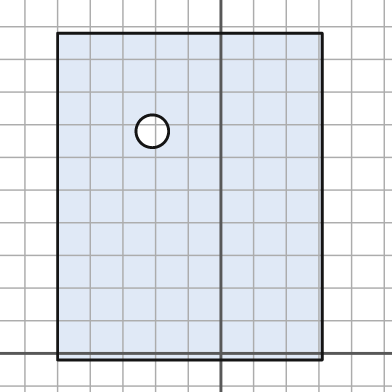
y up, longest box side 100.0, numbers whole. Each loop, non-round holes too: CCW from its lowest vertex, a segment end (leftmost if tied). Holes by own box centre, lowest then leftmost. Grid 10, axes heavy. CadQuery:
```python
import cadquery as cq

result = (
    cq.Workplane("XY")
    .moveTo(-50.0, -2.0)
    .lineTo(31.0, -2.0)
    .lineTo(31.0, 98.0)
    .lineTo(-50.0, 98.0)
    .close()
    .moveTo(-21.0, 68.0)
    .circle(5.0)
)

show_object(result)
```